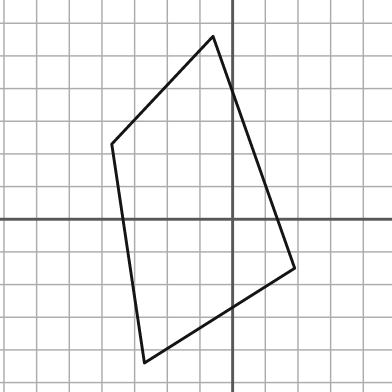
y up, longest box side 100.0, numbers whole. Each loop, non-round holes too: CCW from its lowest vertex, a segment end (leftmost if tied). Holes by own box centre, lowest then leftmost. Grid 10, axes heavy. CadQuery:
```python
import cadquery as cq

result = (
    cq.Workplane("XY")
    .moveTo(-27.0, -44.0)
    .lineTo(19.0, -15.0)
    .lineTo(-6.0, 56.0)
    .lineTo(-37.0, 23.0)
    .close()
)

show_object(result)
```